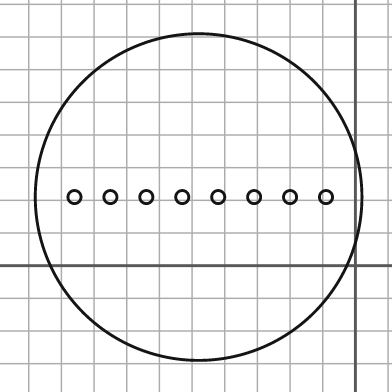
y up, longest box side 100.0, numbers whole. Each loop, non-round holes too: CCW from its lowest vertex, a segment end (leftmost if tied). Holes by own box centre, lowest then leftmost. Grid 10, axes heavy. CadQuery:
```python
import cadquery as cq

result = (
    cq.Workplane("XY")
    .moveTo(-48.0, 21.0)
    .circle(50.0)
    .moveTo(-86.0, 21.0)
    .circle(2.0)
    .moveTo(-75.0, 21.0)
    .circle(2.0)
    .moveTo(-64.0, 21.0)
    .circle(2.0)
    .moveTo(-53.0, 21.0)
    .circle(2.0)
    .moveTo(-42.0, 21.0)
    .circle(2.0)
    .moveTo(-31.0, 21.0)
    .circle(2.0)
    .moveTo(-20.0, 21.0)
    .circle(2.0)
    .moveTo(-9.0, 21.0)
    .circle(2.0)
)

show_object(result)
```